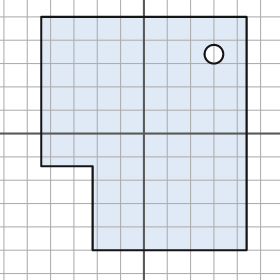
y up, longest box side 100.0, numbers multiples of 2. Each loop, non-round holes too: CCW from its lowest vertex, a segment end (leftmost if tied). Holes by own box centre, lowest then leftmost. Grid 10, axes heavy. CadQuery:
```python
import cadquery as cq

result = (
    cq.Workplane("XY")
    .moveTo(-22.0, -50.0)
    .lineTo(44.0, -50.0)
    .lineTo(44.0, 50.0)
    .lineTo(-44.0, 50.0)
    .lineTo(-44.0, -14.0)
    .lineTo(-22.0, -14.0)
    .close()
    .moveTo(30.0, 34.0)
    .circle(4.0)
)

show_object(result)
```